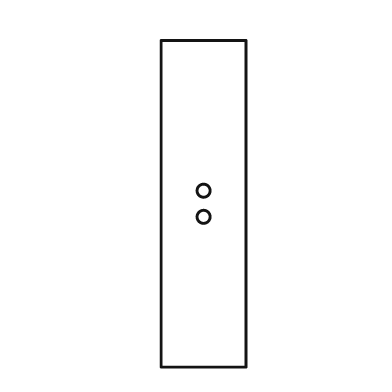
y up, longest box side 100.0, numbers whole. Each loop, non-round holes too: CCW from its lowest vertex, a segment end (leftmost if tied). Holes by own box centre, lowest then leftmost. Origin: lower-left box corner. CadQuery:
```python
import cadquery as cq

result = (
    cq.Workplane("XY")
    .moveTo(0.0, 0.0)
    .lineTo(26.0, 0.0)
    .lineTo(26.0, 100.0)
    .lineTo(0.0, 100.0)
    .close()
    .moveTo(13.0, 46.0)
    .circle(2.0)
    .moveTo(13.0, 54.0)
    .circle(2.0)
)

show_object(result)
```